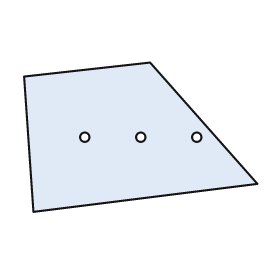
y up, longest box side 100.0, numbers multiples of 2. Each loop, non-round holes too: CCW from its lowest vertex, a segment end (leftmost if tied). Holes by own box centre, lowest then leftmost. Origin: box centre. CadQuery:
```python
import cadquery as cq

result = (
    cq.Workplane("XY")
    .moveTo(-46.0, -32.0)
    .lineTo(50.0, -20.0)
    .lineTo(4.0, 32.0)
    .lineTo(-50.0, 26.0)
    .close()
    .moveTo(-24.0, 0.0)
    .circle(2.0)
    .moveTo(0.0, 0.0)
    .circle(2.0)
    .moveTo(24.0, 0.0)
    .circle(2.0)
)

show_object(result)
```